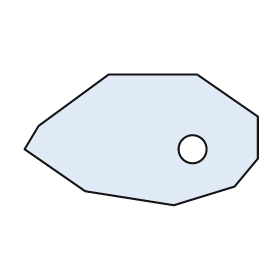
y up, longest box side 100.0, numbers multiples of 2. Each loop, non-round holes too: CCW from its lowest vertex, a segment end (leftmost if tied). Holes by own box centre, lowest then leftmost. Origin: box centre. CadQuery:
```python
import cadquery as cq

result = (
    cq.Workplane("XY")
    .moveTo(14.0, -28.0)
    .lineTo(40.0, -20.0)
    .lineTo(50.0, -8.0)
    .lineTo(50.0, 10.0)
    .lineTo(24.0, 28.0)
    .lineTo(-14.0, 28.0)
    .lineTo(-44.0, 6.0)
    .lineTo(-50.0, -4.0)
    .lineTo(-24.0, -22.0)
    .close()
    .moveTo(22.0, -4.0)
    .circle(6.0)
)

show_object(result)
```